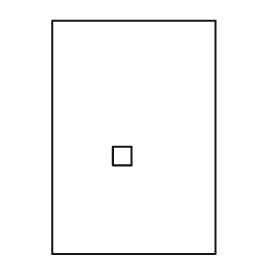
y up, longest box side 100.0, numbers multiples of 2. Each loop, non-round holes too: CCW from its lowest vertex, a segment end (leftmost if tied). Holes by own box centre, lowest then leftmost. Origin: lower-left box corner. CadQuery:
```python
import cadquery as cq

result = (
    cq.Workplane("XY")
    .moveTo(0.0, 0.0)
    .lineTo(70.0, 0.0)
    .lineTo(70.0, 100.0)
    .lineTo(0.0, 100.0)
    .close()
    .moveTo(26.0, 38.0)
    .lineTo(34.0, 38.0)
    .lineTo(34.0, 46.0)
    .lineTo(26.0, 46.0)
    .close()
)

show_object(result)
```